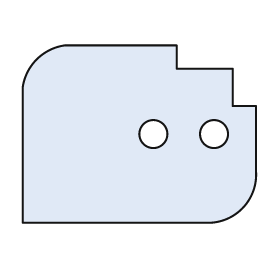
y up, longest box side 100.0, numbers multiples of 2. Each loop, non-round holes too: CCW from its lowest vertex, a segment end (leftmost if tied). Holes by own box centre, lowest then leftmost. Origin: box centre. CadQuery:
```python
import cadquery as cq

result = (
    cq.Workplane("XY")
    .moveTo(-50.0, -38.0)
    .lineTo(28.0, -38.0)
    .threePointArc((44.0, -32.0), (50.0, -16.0))
    .lineTo(50.0, 12.0)
    .lineTo(40.0, 12.0)
    .lineTo(40.0, 28.0)
    .lineTo(16.0, 28.0)
    .lineTo(16.0, 38.0)
    .lineTo(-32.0, 38.0)
    .threePointArc((-44.0, 32.0), (-50.0, 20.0))
    .close()
    .moveTo(6.0, 0.0)
    .circle(6.0)
    .moveTo(32.0, 0.0)
    .circle(6.0)
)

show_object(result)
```